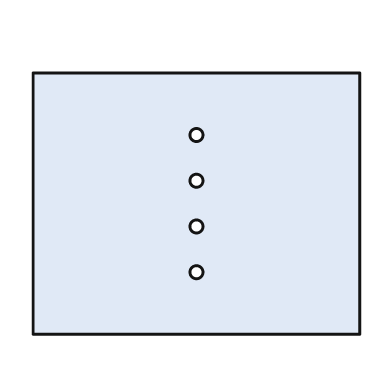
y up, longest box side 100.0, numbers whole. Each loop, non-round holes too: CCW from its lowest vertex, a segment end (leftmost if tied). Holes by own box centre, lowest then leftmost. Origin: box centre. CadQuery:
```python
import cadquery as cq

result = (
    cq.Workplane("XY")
    .moveTo(-50.0, -40.0)
    .lineTo(50.0, -40.0)
    .lineTo(50.0, 40.0)
    .lineTo(-50.0, 40.0)
    .close()
    .moveTo(0.0, -21.0)
    .circle(2.0)
    .moveTo(0.0, -7.0)
    .circle(2.0)
    .moveTo(0.0, 7.0)
    .circle(2.0)
    .moveTo(0.0, 21.0)
    .circle(2.0)
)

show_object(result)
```